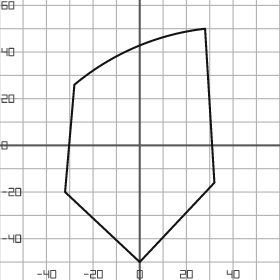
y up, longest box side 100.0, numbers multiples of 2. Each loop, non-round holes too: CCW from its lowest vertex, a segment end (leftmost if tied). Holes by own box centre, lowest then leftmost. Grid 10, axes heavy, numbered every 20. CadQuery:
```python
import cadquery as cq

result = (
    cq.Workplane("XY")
    .moveTo(0.0, -50.0)
    .lineTo(32.0, -16.0)
    .lineTo(28.0, 50.0)
    .threePointArc((-2.0, 42.0), (-28.0, 26.0))
    .lineTo(-32.0, -20.0)
    .close()
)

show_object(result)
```